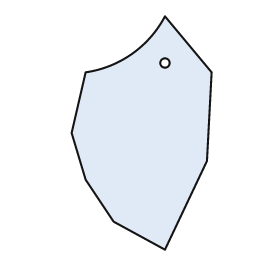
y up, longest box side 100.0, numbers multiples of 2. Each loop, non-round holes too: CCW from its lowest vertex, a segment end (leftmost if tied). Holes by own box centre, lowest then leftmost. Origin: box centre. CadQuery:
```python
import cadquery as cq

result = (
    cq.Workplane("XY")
    .moveTo(10.0, -50.0)
    .lineTo(28.0, -12.0)
    .lineTo(30.0, 26.0)
    .lineTo(10.0, 50.0)
    .threePointArc((-4.0, 34.0), (-24.0, 26.0))
    .lineTo(-30.0, 0.0)
    .lineTo(-24.0, -20.0)
    .lineTo(-12.0, -38.0)
    .close()
    .moveTo(10.0, 30.0)
    .circle(2.0)
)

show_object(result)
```